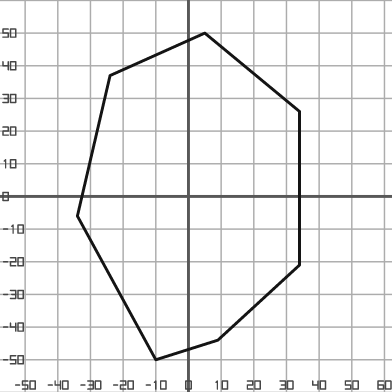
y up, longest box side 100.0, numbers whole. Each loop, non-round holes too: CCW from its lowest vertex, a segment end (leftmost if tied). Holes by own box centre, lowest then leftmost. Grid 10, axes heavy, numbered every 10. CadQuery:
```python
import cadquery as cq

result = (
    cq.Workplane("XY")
    .moveTo(-10.0, -50.0)
    .lineTo(9.0, -44.0)
    .lineTo(34.0, -21.0)
    .lineTo(34.0, 26.0)
    .lineTo(5.0, 50.0)
    .lineTo(-24.0, 37.0)
    .lineTo(-34.0, -6.0)
    .close()
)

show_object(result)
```